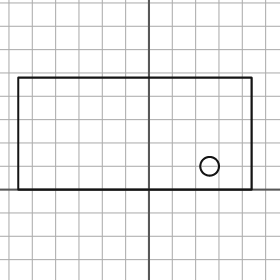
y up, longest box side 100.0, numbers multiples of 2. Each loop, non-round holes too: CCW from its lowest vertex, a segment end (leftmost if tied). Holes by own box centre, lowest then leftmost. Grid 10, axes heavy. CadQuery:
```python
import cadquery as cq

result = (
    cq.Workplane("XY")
    .moveTo(-56.0, 0.0)
    .lineTo(44.0, 0.0)
    .lineTo(44.0, 48.0)
    .lineTo(-56.0, 48.0)
    .close()
    .moveTo(26.0, 10.0)
    .circle(4.0)
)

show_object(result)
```